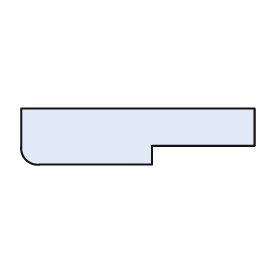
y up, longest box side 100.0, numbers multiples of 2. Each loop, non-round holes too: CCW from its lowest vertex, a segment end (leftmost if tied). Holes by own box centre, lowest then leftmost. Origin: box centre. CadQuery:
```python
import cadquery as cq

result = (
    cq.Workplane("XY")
    .moveTo(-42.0, -12.0)
    .lineTo(6.0, -12.0)
    .lineTo(6.0, -4.0)
    .lineTo(50.0, -4.0)
    .lineTo(50.0, 12.0)
    .lineTo(-50.0, 12.0)
    .lineTo(-50.0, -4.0)
    .threePointArc((-48.0, -10.0), (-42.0, -12.0))
    .close()
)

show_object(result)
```